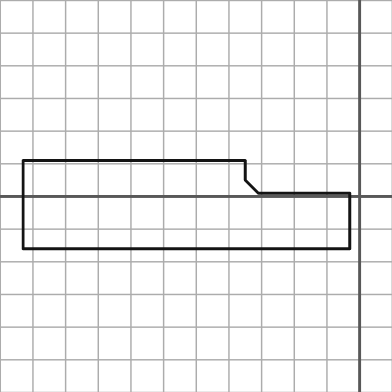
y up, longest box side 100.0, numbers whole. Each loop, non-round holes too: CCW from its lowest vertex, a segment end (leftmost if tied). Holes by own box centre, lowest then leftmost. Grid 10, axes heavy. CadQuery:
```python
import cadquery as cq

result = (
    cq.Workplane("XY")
    .moveTo(-103.0, -16.0)
    .lineTo(-3.0, -16.0)
    .lineTo(-3.0, 1.0)
    .lineTo(-31.0, 1.0)
    .lineTo(-35.0, 5.0)
    .lineTo(-35.0, 11.0)
    .lineTo(-103.0, 11.0)
    .close()
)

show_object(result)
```